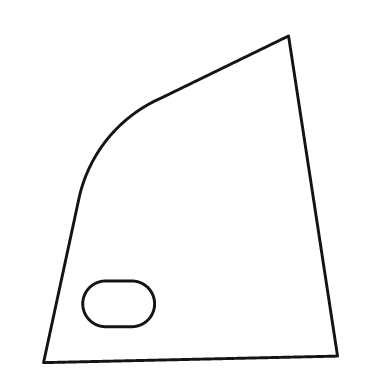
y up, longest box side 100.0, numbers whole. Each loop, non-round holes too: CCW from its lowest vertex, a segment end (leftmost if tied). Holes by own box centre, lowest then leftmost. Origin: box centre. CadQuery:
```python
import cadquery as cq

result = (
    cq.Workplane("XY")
    .moveTo(-45.0, -50.0)
    .lineTo(45.0, -48.0)
    .lineTo(30.0, 50.0)
    .lineTo(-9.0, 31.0)
    .threePointArc((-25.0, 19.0), (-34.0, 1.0))
    .close()
    .moveTo(-26.0, -39.0)
    .lineTo(-18.0, -39.0)
    .threePointArc((-11.0, -32.0), (-18.0, -25.0))
    .lineTo(-26.0, -25.0)
    .threePointArc((-33.0, -32.0), (-26.0, -39.0))
    .close()
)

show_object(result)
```